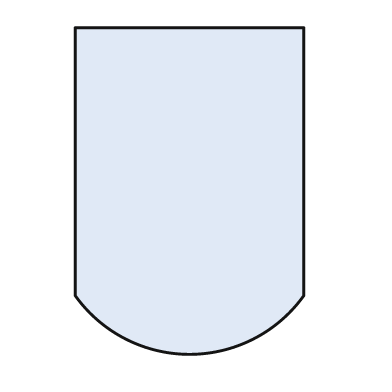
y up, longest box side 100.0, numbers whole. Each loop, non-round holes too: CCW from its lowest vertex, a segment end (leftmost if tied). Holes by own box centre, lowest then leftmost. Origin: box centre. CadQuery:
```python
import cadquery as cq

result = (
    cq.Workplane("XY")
    .moveTo(-35.0, -32.0)
    .threePointArc((0.0, -50.0), (35.0, -32.0))
    .lineTo(35.0, 50.0)
    .lineTo(-35.0, 50.0)
    .close()
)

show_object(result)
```